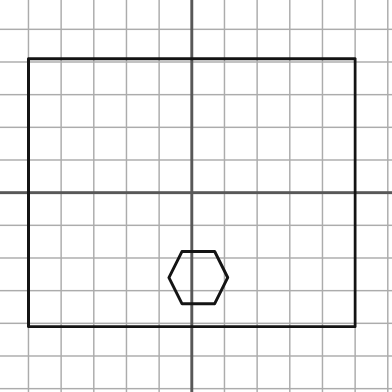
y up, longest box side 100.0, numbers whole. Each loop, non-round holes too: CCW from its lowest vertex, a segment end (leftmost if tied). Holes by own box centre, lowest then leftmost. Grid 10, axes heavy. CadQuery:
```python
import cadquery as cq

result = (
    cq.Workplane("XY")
    .moveTo(-50.0, -41.0)
    .lineTo(50.0, -41.0)
    .lineTo(50.0, 41.0)
    .lineTo(-50.0, 41.0)
    .close()
    .moveTo(-3.0, -34.0)
    .lineTo(7.0, -34.0)
    .lineTo(11.0, -26.0)
    .lineTo(7.0, -18.0)
    .lineTo(-3.0, -18.0)
    .lineTo(-7.0, -26.0)
    .close()
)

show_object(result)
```